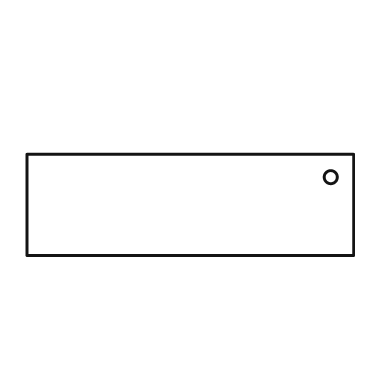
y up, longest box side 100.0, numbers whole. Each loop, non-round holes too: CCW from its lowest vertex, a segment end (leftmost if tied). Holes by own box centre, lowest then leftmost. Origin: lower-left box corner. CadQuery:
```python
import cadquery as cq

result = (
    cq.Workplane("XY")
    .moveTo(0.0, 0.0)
    .lineTo(100.0, 0.0)
    .lineTo(100.0, 31.0)
    .lineTo(0.0, 31.0)
    .close()
    .moveTo(93.0, 24.0)
    .circle(2.0)
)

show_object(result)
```